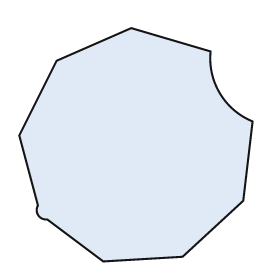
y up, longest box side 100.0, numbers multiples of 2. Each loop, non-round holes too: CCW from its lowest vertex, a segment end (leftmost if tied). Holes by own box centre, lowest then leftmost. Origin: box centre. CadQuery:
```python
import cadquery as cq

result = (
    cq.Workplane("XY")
    .moveTo(-14.0, -50.0)
    .lineTo(20.0, -48.0)
    .lineTo(46.0, -24.0)
    .lineTo(50.0, 10.0)
    .threePointArc((36.0, 22.0), (32.0, 40.0))
    .lineTo(-2.0, 50.0)
    .lineTo(-34.0, 36.0)
    .lineTo(-50.0, 4.0)
    .lineTo(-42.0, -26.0)
    .threePointArc((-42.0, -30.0), (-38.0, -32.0))
    .close()
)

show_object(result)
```